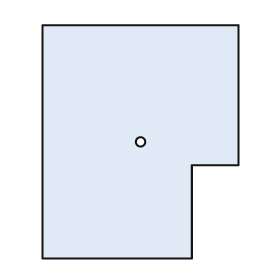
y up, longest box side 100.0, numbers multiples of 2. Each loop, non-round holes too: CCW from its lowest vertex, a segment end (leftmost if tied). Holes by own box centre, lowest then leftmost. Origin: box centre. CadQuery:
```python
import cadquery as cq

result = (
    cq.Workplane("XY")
    .moveTo(-42.0, -50.0)
    .lineTo(22.0, -50.0)
    .lineTo(22.0, -10.0)
    .lineTo(42.0, -10.0)
    .lineTo(42.0, 50.0)
    .lineTo(-42.0, 50.0)
    .close()
    .moveTo(0.0, 0.0)
    .circle(2.0)
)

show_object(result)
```